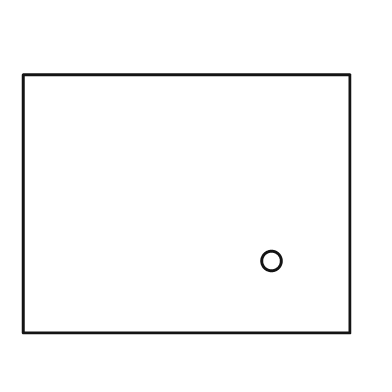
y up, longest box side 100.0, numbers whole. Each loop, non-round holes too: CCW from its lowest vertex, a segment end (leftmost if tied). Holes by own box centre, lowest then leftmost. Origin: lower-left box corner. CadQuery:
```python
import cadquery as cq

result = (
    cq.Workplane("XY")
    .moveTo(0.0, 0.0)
    .lineTo(100.0, 0.0)
    .lineTo(100.0, 79.0)
    .lineTo(0.0, 79.0)
    .close()
    .moveTo(76.0, 22.0)
    .circle(3.0)
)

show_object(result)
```